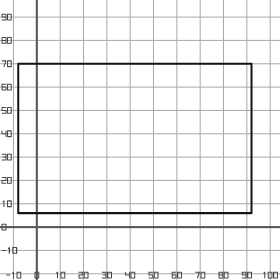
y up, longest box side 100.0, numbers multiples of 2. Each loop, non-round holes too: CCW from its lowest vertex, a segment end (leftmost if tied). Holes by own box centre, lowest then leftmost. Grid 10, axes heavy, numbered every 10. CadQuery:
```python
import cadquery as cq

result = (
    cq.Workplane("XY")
    .moveTo(-8.0, 6.0)
    .lineTo(92.0, 6.0)
    .lineTo(92.0, 70.0)
    .lineTo(-8.0, 70.0)
    .close()
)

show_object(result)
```